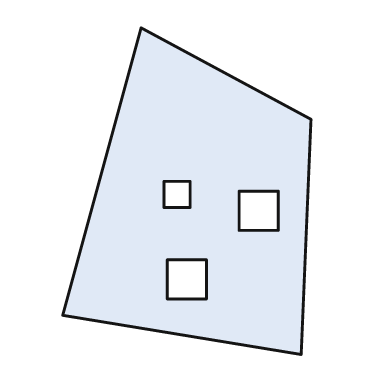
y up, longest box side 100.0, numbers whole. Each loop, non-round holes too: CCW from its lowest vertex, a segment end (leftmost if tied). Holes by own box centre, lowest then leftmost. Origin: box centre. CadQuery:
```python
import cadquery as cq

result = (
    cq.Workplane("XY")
    .moveTo(35.0, -50.0)
    .lineTo(38.0, 22.0)
    .lineTo(-14.0, 50.0)
    .lineTo(-38.0, -38.0)
    .close()
    .moveTo(-6.0, -33.0)
    .lineTo(6.0, -33.0)
    .lineTo(6.0, -21.0)
    .lineTo(-6.0, -21.0)
    .close()
    .moveTo(16.0, -12.0)
    .lineTo(28.0, -12.0)
    .lineTo(28.0, 0.0)
    .lineTo(16.0, 0.0)
    .close()
    .moveTo(-7.0, -5.0)
    .lineTo(1.0, -5.0)
    .lineTo(1.0, 3.0)
    .lineTo(-7.0, 3.0)
    .close()
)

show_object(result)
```